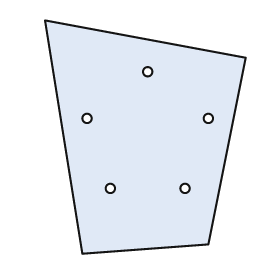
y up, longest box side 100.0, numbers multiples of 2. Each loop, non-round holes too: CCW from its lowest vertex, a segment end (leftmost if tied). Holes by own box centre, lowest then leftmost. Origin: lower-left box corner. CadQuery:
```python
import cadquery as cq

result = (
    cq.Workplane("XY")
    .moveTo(16.0, 0.0)
    .lineTo(70.0, 4.0)
    .lineTo(86.0, 84.0)
    .lineTo(0.0, 100.0)
    .close()
    .moveTo(28.0, 28.0)
    .circle(2.0)
    .moveTo(60.0, 28.0)
    .circle(2.0)
    .moveTo(18.0, 58.0)
    .circle(2.0)
    .moveTo(70.0, 58.0)
    .circle(2.0)
    .moveTo(44.0, 78.0)
    .circle(2.0)
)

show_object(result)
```